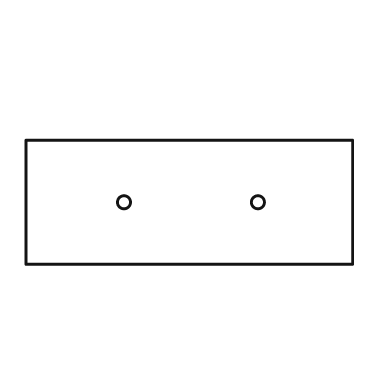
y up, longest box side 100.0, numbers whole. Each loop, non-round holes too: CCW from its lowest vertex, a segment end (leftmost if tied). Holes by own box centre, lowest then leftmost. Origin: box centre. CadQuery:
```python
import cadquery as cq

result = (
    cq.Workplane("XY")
    .moveTo(-50.0, -19.0)
    .lineTo(50.0, -19.0)
    .lineTo(50.0, 19.0)
    .lineTo(-50.0, 19.0)
    .close()
    .moveTo(-20.0, 0.0)
    .circle(2.0)
    .moveTo(21.0, 0.0)
    .circle(2.0)
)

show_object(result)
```